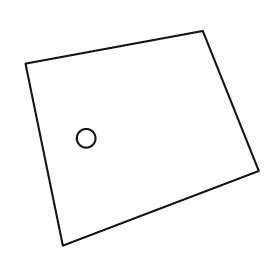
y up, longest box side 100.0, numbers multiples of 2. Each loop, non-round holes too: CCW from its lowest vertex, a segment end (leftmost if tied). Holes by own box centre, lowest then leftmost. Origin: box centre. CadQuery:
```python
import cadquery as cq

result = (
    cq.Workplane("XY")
    .moveTo(-34.0, -46.0)
    .lineTo(50.0, -14.0)
    .lineTo(26.0, 46.0)
    .lineTo(-50.0, 32.0)
    .close()
    .moveTo(-24.0, 0.0)
    .circle(4.0)
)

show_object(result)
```